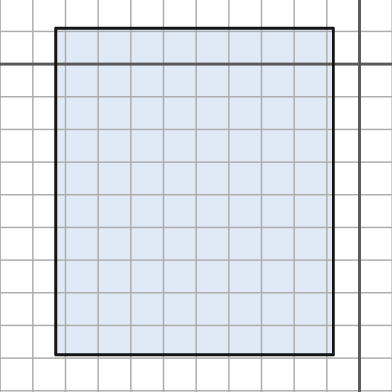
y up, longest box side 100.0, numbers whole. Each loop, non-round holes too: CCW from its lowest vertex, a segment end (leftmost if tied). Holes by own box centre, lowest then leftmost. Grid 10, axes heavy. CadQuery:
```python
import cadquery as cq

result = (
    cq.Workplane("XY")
    .moveTo(-93.0, -89.0)
    .lineTo(-8.0, -89.0)
    .lineTo(-8.0, 11.0)
    .lineTo(-93.0, 11.0)
    .close()
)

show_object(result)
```